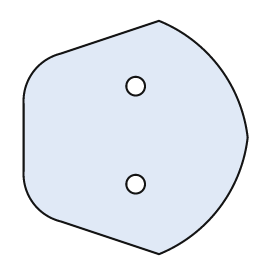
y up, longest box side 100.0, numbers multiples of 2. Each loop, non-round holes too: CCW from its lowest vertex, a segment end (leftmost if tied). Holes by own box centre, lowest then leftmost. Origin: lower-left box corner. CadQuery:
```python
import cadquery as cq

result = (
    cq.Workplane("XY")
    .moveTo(58.0, 0.0)
    .threePointArc((84.0, 20.0), (96.0, 50.0))
    .threePointArc((84.0, 80.0), (58.0, 100.0))
    .lineTo(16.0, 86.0)
    .threePointArc((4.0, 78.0), (0.0, 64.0))
    .lineTo(0.0, 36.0)
    .threePointArc((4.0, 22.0), (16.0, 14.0))
    .close()
    .moveTo(48.0, 30.0)
    .circle(4.0)
    .moveTo(48.0, 72.0)
    .circle(4.0)
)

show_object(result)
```